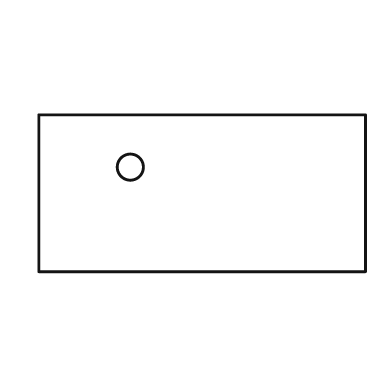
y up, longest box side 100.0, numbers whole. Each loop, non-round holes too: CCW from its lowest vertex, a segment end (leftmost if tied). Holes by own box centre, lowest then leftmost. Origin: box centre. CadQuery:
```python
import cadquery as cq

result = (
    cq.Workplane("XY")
    .moveTo(-50.0, -24.0)
    .lineTo(50.0, -24.0)
    .lineTo(50.0, 24.0)
    .lineTo(-50.0, 24.0)
    .close()
    .moveTo(-22.0, 8.0)
    .circle(4.0)
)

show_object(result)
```